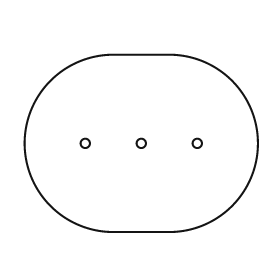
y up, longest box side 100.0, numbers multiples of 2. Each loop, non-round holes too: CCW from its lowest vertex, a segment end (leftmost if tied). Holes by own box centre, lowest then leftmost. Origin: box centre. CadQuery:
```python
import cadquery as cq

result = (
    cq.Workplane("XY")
    .moveTo(-12.0, -38.0)
    .lineTo(12.0, -38.0)
    .threePointArc((50.0, 0.0), (12.0, 38.0))
    .lineTo(-12.0, 38.0)
    .threePointArc((-50.0, 0.0), (-12.0, -38.0))
    .close()
    .moveTo(-24.0, 0.0)
    .circle(2.0)
    .moveTo(0.0, 0.0)
    .circle(2.0)
    .moveTo(24.0, 0.0)
    .circle(2.0)
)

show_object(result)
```